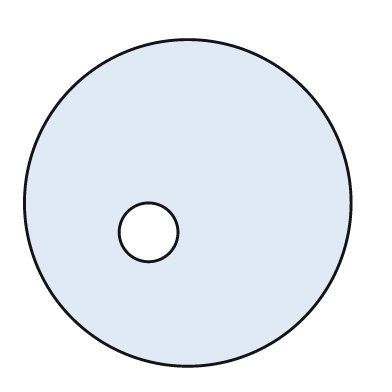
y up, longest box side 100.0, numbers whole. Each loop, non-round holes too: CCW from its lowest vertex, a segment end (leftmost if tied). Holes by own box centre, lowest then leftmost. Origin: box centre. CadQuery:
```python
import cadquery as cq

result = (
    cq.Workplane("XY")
    .moveTo(0.0, 0.0)
    .circle(50.0)
    .moveTo(-12.0, -9.0)
    .circle(9.0)
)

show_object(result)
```